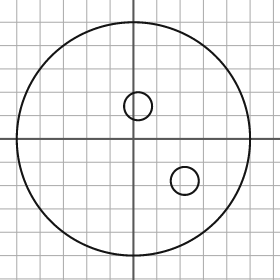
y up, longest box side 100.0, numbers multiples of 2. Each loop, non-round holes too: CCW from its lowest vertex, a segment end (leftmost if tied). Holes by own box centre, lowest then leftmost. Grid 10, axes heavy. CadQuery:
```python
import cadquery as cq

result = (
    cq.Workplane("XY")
    .moveTo(0.0, 0.0)
    .circle(50.0)
    .moveTo(22.0, -18.0)
    .circle(6.0)
    .moveTo(2.0, 14.0)
    .circle(6.0)
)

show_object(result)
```